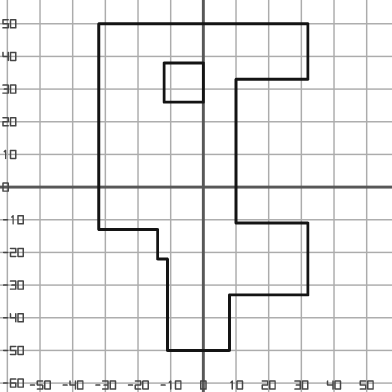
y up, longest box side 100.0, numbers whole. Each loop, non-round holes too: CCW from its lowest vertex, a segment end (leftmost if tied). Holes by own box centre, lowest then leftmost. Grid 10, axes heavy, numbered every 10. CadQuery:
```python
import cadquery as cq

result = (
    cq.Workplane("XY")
    .moveTo(-11.0, -50.0)
    .lineTo(8.0, -50.0)
    .lineTo(8.0, -33.0)
    .lineTo(32.0, -33.0)
    .lineTo(32.0, -11.0)
    .lineTo(10.0, -11.0)
    .lineTo(10.0, 33.0)
    .lineTo(32.0, 33.0)
    .lineTo(32.0, 50.0)
    .lineTo(-32.0, 50.0)
    .lineTo(-32.0, -13.0)
    .lineTo(-14.0, -13.0)
    .lineTo(-14.0, -22.0)
    .lineTo(-11.0, -22.0)
    .close()
    .moveTo(-12.0, 26.0)
    .lineTo(0.0, 26.0)
    .lineTo(0.0, 38.0)
    .lineTo(-12.0, 38.0)
    .close()
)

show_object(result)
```